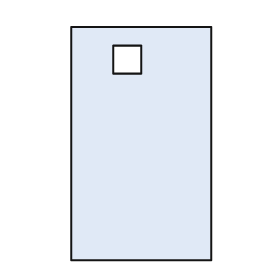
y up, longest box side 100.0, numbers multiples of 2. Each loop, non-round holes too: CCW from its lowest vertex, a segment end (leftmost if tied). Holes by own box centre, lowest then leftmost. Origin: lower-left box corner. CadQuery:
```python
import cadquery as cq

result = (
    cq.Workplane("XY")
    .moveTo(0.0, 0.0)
    .lineTo(60.0, 0.0)
    .lineTo(60.0, 100.0)
    .lineTo(0.0, 100.0)
    .close()
    .moveTo(18.0, 80.0)
    .lineTo(30.0, 80.0)
    .lineTo(30.0, 92.0)
    .lineTo(18.0, 92.0)
    .close()
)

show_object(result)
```